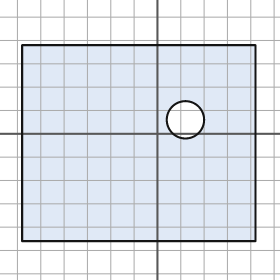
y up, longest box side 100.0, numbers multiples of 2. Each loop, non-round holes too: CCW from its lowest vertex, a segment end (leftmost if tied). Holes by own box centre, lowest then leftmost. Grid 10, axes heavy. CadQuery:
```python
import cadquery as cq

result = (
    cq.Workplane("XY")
    .moveTo(-58.0, -46.0)
    .lineTo(42.0, -46.0)
    .lineTo(42.0, 38.0)
    .lineTo(-58.0, 38.0)
    .close()
    .moveTo(12.0, 6.0)
    .circle(8.0)
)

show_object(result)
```